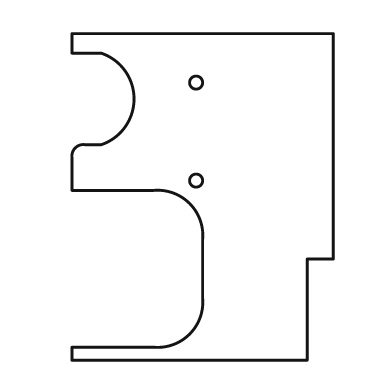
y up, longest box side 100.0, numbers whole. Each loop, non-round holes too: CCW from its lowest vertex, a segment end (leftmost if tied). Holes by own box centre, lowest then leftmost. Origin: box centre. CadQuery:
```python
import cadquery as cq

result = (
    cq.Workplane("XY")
    .moveTo(-40.0, -50.0)
    .lineTo(32.0, -50.0)
    .lineTo(32.0, -19.0)
    .lineTo(40.0, -19.0)
    .lineTo(40.0, 50.0)
    .lineTo(-40.0, 50.0)
    .lineTo(-40.0, 44.0)
    .lineTo(-31.0, 44.0)
    .threePointArc((-21.0, 30.0), (-31.0, 16.0))
    .lineTo(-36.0, 16.0)
    .threePointArc((-39.0, 15.0), (-40.0, 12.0))
    .lineTo(-40.0, 2.0)
    .lineTo(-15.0, 2.0)
    .threePointArc((-4.0, -2.0), (0.0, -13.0))
    .lineTo(0.0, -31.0)
    .threePointArc((-4.0, -42.0), (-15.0, -46.0))
    .lineTo(-40.0, -46.0)
    .close()
    .moveTo(-2.0, 5.0)
    .circle(2.0)
    .moveTo(-2.0, 35.0)
    .circle(2.0)
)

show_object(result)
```